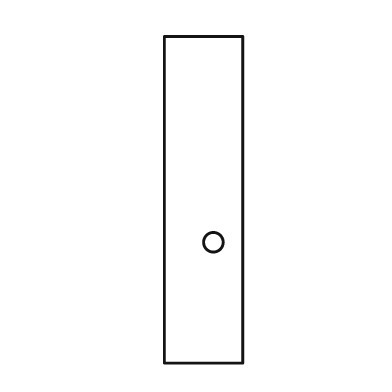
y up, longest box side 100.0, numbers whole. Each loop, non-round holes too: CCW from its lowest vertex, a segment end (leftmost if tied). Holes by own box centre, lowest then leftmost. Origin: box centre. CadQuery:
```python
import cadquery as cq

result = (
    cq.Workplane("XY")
    .moveTo(-12.0, -50.0)
    .lineTo(12.0, -50.0)
    .lineTo(12.0, 50.0)
    .lineTo(-12.0, 50.0)
    .close()
    .moveTo(3.0, -13.0)
    .circle(3.0)
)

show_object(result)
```